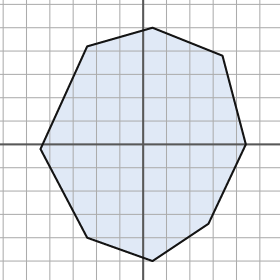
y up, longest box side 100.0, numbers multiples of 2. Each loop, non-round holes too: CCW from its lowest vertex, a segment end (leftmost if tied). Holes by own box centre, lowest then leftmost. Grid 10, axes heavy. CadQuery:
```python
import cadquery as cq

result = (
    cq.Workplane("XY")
    .moveTo(4.0, -50.0)
    .lineTo(28.0, -34.0)
    .lineTo(44.0, 0.0)
    .lineTo(34.0, 38.0)
    .lineTo(4.0, 50.0)
    .lineTo(-24.0, 42.0)
    .lineTo(-44.0, -2.0)
    .lineTo(-24.0, -40.0)
    .close()
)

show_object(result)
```